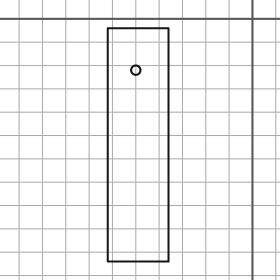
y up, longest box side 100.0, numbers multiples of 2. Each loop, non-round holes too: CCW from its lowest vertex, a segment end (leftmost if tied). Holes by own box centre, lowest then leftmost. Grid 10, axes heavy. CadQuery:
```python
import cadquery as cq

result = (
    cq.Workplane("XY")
    .moveTo(-62.0, -104.0)
    .lineTo(-36.0, -104.0)
    .lineTo(-36.0, -4.0)
    .lineTo(-62.0, -4.0)
    .close()
    .moveTo(-50.0, -22.0)
    .circle(2.0)
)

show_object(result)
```